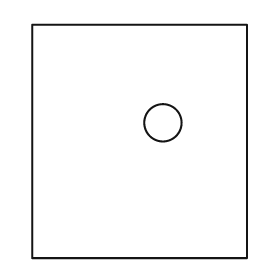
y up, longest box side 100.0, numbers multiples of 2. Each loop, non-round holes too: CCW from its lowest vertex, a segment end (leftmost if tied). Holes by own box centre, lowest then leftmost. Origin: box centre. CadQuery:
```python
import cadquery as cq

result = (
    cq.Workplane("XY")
    .moveTo(-46.0, -50.0)
    .lineTo(46.0, -50.0)
    .lineTo(46.0, 50.0)
    .lineTo(-46.0, 50.0)
    .close()
    .moveTo(10.0, 8.0)
    .circle(8.0)
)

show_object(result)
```